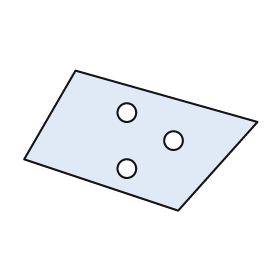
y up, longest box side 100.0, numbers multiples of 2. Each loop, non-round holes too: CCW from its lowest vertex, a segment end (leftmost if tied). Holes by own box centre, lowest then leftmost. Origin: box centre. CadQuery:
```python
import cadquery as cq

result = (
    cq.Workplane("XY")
    .moveTo(16.0, -30.0)
    .lineTo(50.0, 8.0)
    .lineTo(-28.0, 30.0)
    .lineTo(-50.0, -8.0)
    .close()
    .moveTo(-6.0, -12.0)
    .circle(4.0)
    .moveTo(14.0, 0.0)
    .circle(4.0)
    .moveTo(-6.0, 12.0)
    .circle(4.0)
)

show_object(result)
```